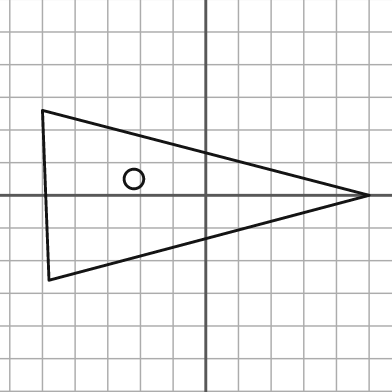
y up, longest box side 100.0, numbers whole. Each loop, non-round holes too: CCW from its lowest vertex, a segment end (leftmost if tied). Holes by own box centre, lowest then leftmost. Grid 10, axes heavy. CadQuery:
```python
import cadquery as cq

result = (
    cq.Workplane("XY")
    .moveTo(-48.0, -26.0)
    .lineTo(50.0, 0.0)
    .lineTo(-50.0, 26.0)
    .close()
    .moveTo(-22.0, 5.0)
    .circle(3.0)
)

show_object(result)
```